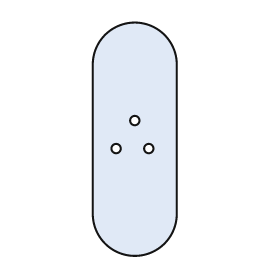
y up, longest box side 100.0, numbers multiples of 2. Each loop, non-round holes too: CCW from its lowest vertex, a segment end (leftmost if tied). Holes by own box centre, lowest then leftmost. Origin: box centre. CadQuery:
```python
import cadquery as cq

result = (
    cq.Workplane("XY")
    .moveTo(-18.0, -32.0)
    .threePointArc((0.0, -50.0), (18.0, -32.0))
    .lineTo(18.0, 32.0)
    .threePointArc((0.0, 50.0), (-18.0, 32.0))
    .close()
    .moveTo(-8.0, -4.0)
    .circle(2.0)
    .moveTo(6.0, -4.0)
    .circle(2.0)
    .moveTo(0.0, 8.0)
    .circle(2.0)
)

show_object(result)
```